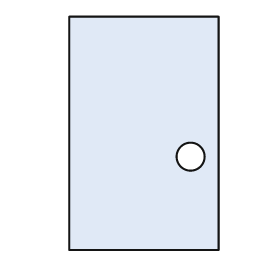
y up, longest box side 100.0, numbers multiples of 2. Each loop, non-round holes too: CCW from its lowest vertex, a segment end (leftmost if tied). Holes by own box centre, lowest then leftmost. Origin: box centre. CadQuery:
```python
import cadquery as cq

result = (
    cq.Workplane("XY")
    .moveTo(-32.0, -50.0)
    .lineTo(32.0, -50.0)
    .lineTo(32.0, 50.0)
    .lineTo(-32.0, 50.0)
    .close()
    .moveTo(20.0, -10.0)
    .circle(6.0)
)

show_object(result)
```